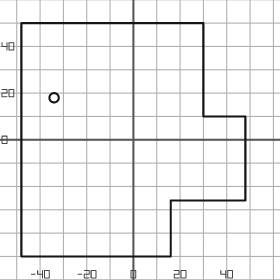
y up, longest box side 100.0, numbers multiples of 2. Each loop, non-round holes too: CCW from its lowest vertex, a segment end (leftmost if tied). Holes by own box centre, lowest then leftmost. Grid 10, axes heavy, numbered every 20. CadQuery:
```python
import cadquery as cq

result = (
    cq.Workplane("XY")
    .moveTo(-48.0, -50.0)
    .lineTo(16.0, -50.0)
    .lineTo(16.0, -26.0)
    .lineTo(48.0, -26.0)
    .lineTo(48.0, 10.0)
    .lineTo(30.0, 10.0)
    .lineTo(30.0, 50.0)
    .lineTo(-48.0, 50.0)
    .close()
    .moveTo(-34.0, 18.0)
    .circle(2.0)
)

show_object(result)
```